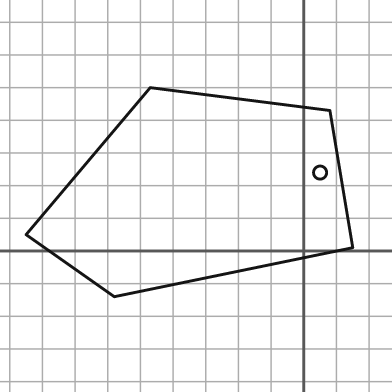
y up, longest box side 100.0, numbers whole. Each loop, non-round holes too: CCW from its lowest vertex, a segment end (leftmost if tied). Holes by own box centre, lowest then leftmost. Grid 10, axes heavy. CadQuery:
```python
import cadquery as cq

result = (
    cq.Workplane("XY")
    .moveTo(-58.0, -14.0)
    .lineTo(15.0, 1.0)
    .lineTo(8.0, 43.0)
    .lineTo(-47.0, 50.0)
    .lineTo(-85.0, 5.0)
    .close()
    .moveTo(5.0, 24.0)
    .circle(2.0)
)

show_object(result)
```